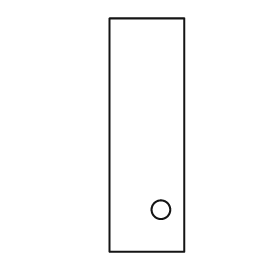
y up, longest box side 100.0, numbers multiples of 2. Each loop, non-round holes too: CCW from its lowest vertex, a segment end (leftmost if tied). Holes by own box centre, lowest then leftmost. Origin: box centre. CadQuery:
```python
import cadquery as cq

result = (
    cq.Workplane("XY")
    .moveTo(-16.0, -50.0)
    .lineTo(16.0, -50.0)
    .lineTo(16.0, 50.0)
    .lineTo(-16.0, 50.0)
    .close()
    .moveTo(6.0, -32.0)
    .circle(4.0)
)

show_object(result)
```